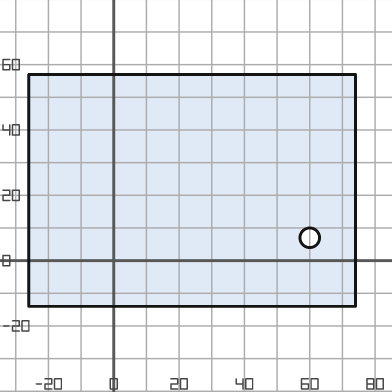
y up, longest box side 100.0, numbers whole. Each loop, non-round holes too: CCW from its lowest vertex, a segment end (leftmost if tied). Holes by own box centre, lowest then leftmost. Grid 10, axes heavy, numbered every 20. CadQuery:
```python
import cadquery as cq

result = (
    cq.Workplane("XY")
    .moveTo(-26.0, -14.0)
    .lineTo(74.0, -14.0)
    .lineTo(74.0, 57.0)
    .lineTo(-26.0, 57.0)
    .close()
    .moveTo(60.0, 7.0)
    .circle(3.0)
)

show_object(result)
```